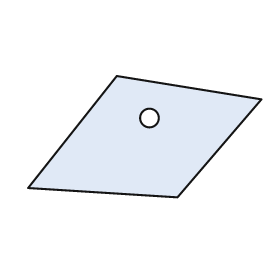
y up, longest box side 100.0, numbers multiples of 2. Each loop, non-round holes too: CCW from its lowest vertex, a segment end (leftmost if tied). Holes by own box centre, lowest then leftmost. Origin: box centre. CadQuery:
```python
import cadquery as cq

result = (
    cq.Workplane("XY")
    .moveTo(14.0, -26.0)
    .lineTo(50.0, 16.0)
    .lineTo(-12.0, 26.0)
    .lineTo(-50.0, -22.0)
    .close()
    .moveTo(2.0, 8.0)
    .circle(4.0)
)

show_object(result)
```